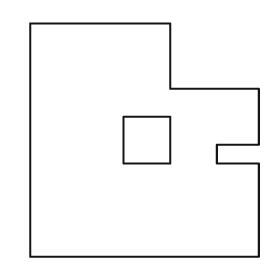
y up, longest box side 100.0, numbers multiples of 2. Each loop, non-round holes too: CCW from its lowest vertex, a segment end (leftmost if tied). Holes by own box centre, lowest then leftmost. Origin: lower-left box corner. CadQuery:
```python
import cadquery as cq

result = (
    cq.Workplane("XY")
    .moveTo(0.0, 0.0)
    .lineTo(98.0, 0.0)
    .lineTo(98.0, 40.0)
    .lineTo(80.0, 40.0)
    .lineTo(80.0, 48.0)
    .lineTo(98.0, 48.0)
    .lineTo(98.0, 72.0)
    .lineTo(60.0, 72.0)
    .lineTo(60.0, 100.0)
    .lineTo(0.0, 100.0)
    .close()
    .moveTo(40.0, 40.0)
    .lineTo(60.0, 40.0)
    .lineTo(60.0, 60.0)
    .lineTo(40.0, 60.0)
    .close()
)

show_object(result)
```